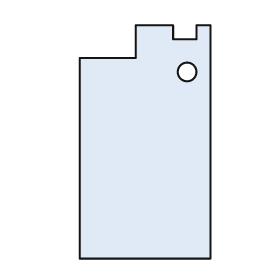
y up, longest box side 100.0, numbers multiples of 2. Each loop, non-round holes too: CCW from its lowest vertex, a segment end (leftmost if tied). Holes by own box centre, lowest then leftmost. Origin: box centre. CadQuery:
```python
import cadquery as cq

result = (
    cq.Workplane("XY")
    .moveTo(-28.0, -50.0)
    .lineTo(28.0, -50.0)
    .lineTo(28.0, 50.0)
    .lineTo(22.0, 50.0)
    .lineTo(22.0, 44.0)
    .lineTo(12.0, 44.0)
    .lineTo(12.0, 50.0)
    .lineTo(-4.0, 50.0)
    .lineTo(-4.0, 36.0)
    .lineTo(-28.0, 36.0)
    .close()
    .moveTo(18.0, 30.0)
    .circle(4.0)
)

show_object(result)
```